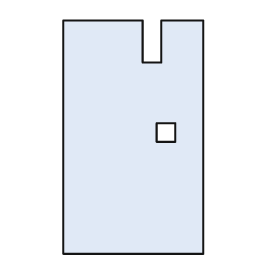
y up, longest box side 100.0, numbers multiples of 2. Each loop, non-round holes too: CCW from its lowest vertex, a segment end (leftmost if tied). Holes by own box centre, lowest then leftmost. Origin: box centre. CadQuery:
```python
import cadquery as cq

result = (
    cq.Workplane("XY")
    .moveTo(-30.0, -50.0)
    .lineTo(30.0, -50.0)
    .lineTo(30.0, 50.0)
    .lineTo(12.0, 50.0)
    .lineTo(12.0, 32.0)
    .lineTo(4.0, 32.0)
    .lineTo(4.0, 50.0)
    .lineTo(-30.0, 50.0)
    .close()
    .moveTo(10.0, -2.0)
    .lineTo(18.0, -2.0)
    .lineTo(18.0, 6.0)
    .lineTo(10.0, 6.0)
    .close()
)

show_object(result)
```